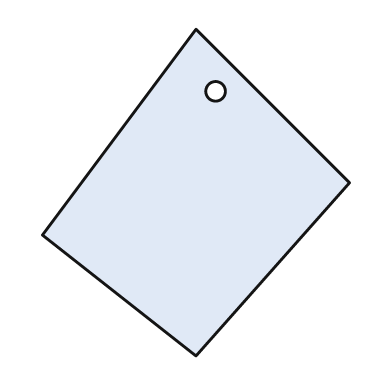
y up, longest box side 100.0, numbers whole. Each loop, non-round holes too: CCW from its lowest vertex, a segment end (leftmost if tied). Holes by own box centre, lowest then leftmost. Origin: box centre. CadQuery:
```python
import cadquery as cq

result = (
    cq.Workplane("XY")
    .moveTo(0.0, -50.0)
    .lineTo(47.0, 3.0)
    .lineTo(0.0, 50.0)
    .lineTo(-47.0, -13.0)
    .close()
    .moveTo(6.0, 31.0)
    .circle(3.0)
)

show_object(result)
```